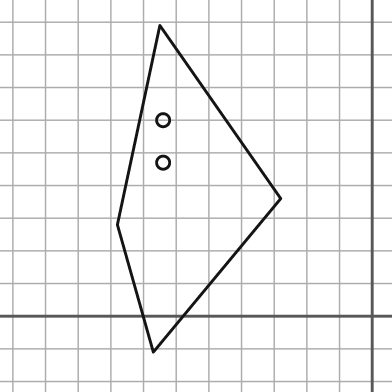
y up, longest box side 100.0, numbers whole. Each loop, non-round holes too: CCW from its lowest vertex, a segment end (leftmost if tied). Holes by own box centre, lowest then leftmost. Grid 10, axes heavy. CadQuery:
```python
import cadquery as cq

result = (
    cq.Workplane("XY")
    .moveTo(-67.0, -11.0)
    .lineTo(-28.0, 36.0)
    .lineTo(-65.0, 89.0)
    .lineTo(-78.0, 28.0)
    .close()
    .moveTo(-64.0, 47.0)
    .circle(2.0)
    .moveTo(-64.0, 60.0)
    .circle(2.0)
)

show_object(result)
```